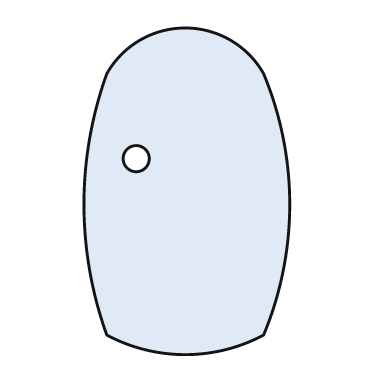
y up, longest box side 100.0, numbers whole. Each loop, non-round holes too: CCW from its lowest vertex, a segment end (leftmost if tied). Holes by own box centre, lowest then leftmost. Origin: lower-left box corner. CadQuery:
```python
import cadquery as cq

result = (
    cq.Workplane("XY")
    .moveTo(7.0, 6.0)
    .threePointArc((31.0, 0.0), (55.0, 6.0))
    .threePointArc((63.0, 46.0), (55.0, 86.0))
    .threePointArc((31.0, 100.0), (7.0, 86.0))
    .threePointArc((0.0, 46.0), (7.0, 6.0))
    .close()
    .moveTo(16.0, 60.0)
    .circle(4.0)
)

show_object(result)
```